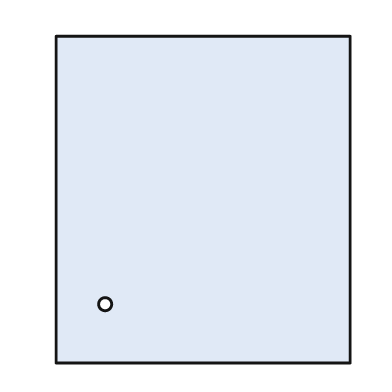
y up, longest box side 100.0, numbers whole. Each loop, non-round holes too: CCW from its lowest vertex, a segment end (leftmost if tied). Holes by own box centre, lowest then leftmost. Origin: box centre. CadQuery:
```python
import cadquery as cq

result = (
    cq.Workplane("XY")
    .moveTo(-45.0, -50.0)
    .lineTo(45.0, -50.0)
    .lineTo(45.0, 50.0)
    .lineTo(-45.0, 50.0)
    .close()
    .moveTo(-30.0, -32.0)
    .circle(2.0)
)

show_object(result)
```